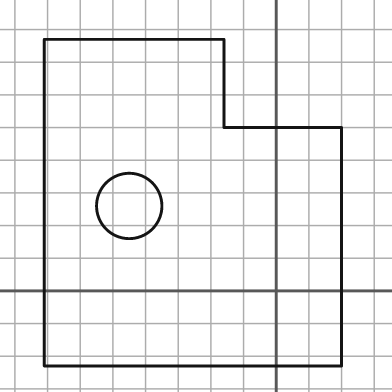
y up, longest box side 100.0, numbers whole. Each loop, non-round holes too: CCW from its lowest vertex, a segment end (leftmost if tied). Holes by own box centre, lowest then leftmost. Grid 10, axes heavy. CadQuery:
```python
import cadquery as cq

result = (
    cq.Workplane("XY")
    .moveTo(-71.0, -23.0)
    .lineTo(20.0, -23.0)
    .lineTo(20.0, 50.0)
    .lineTo(-16.0, 50.0)
    .lineTo(-16.0, 77.0)
    .lineTo(-71.0, 77.0)
    .close()
    .moveTo(-45.0, 26.0)
    .circle(10.0)
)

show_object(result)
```